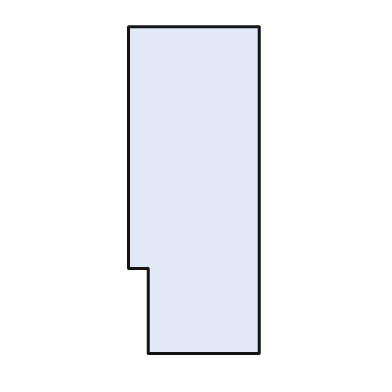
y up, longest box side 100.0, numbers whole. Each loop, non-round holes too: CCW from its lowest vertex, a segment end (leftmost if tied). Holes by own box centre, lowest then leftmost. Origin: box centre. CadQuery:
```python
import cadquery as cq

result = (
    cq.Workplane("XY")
    .moveTo(-14.0, -50.0)
    .lineTo(20.0, -50.0)
    .lineTo(20.0, 50.0)
    .lineTo(-20.0, 50.0)
    .lineTo(-20.0, -24.0)
    .lineTo(-14.0, -24.0)
    .close()
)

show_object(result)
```